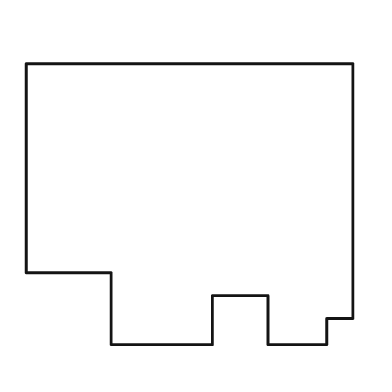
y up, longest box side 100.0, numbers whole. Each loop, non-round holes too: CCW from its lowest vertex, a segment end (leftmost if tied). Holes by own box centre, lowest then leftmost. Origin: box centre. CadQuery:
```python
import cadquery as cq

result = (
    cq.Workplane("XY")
    .moveTo(-24.0, -43.0)
    .lineTo(7.0, -43.0)
    .lineTo(7.0, -28.0)
    .lineTo(24.0, -28.0)
    .lineTo(24.0, -43.0)
    .lineTo(42.0, -43.0)
    .lineTo(42.0, -35.0)
    .lineTo(50.0, -35.0)
    .lineTo(50.0, 43.0)
    .lineTo(-50.0, 43.0)
    .lineTo(-50.0, -21.0)
    .lineTo(-24.0, -21.0)
    .close()
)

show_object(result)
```